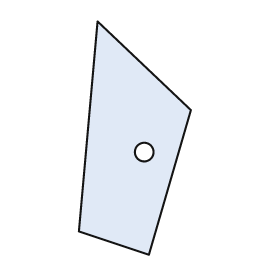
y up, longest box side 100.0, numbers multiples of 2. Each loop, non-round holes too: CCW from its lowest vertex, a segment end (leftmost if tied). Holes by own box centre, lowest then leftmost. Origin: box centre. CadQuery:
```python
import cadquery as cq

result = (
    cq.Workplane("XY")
    .moveTo(6.0, -50.0)
    .lineTo(24.0, 12.0)
    .lineTo(-16.0, 50.0)
    .lineTo(-24.0, -40.0)
    .close()
    .moveTo(4.0, -6.0)
    .circle(4.0)
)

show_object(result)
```